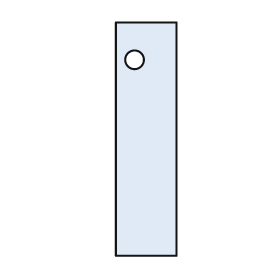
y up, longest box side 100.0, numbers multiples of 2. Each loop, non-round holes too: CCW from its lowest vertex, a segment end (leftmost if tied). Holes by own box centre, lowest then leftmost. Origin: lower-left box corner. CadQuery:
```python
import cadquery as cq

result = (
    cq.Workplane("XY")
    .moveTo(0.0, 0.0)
    .lineTo(26.0, 0.0)
    .lineTo(26.0, 100.0)
    .lineTo(0.0, 100.0)
    .close()
    .moveTo(8.0, 84.0)
    .circle(4.0)
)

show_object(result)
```